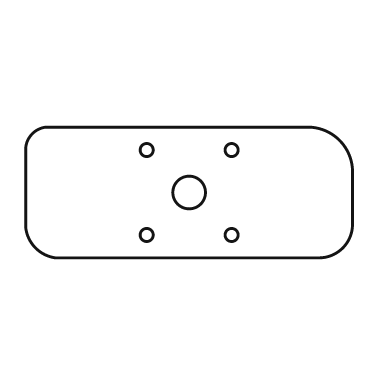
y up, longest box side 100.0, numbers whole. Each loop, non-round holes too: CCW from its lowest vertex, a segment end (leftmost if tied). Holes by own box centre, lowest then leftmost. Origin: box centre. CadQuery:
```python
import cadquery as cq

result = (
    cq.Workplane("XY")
    .moveTo(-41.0, -20.0)
    .lineTo(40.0, -20.0)
    .threePointArc((47.0, -17.0), (50.0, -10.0))
    .lineTo(50.0, 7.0)
    .threePointArc((46.0, 16.0), (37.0, 20.0))
    .lineTo(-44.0, 20.0)
    .threePointArc((-48.0, 18.0), (-50.0, 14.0))
    .lineTo(-50.0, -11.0)
    .threePointArc((-47.0, -17.0), (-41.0, -20.0))
    .close()
    .moveTo(-13.0, -13.0)
    .circle(2.0)
    .moveTo(13.0, -13.0)
    .circle(2.0)
    .moveTo(0.0, 0.0)
    .circle(5.0)
    .moveTo(-13.0, 13.0)
    .circle(2.0)
    .moveTo(13.0, 13.0)
    .circle(2.0)
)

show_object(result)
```